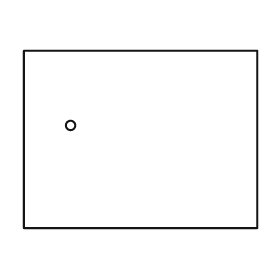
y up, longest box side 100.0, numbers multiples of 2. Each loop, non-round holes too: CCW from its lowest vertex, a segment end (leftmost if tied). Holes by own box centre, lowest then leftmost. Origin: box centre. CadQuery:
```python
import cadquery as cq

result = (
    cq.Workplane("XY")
    .moveTo(-50.0, -38.0)
    .lineTo(50.0, -38.0)
    .lineTo(50.0, 38.0)
    .lineTo(-50.0, 38.0)
    .close()
    .moveTo(-30.0, 6.0)
    .circle(2.0)
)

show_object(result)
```